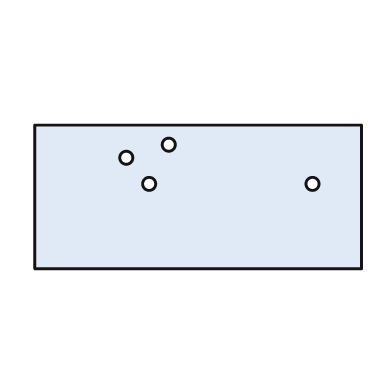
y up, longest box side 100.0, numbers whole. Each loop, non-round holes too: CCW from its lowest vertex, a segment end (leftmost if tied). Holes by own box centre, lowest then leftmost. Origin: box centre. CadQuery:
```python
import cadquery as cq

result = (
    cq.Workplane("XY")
    .moveTo(-50.0, -22.0)
    .lineTo(50.0, -22.0)
    .lineTo(50.0, 22.0)
    .lineTo(-50.0, 22.0)
    .close()
    .moveTo(-15.0, 4.0)
    .circle(2.0)
    .moveTo(35.0, 4.0)
    .circle(2.0)
    .moveTo(-22.0, 12.0)
    .circle(2.0)
    .moveTo(-9.0, 16.0)
    .circle(2.0)
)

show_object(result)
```